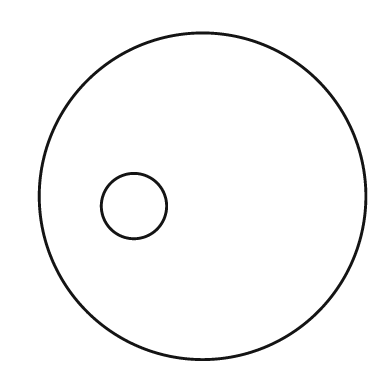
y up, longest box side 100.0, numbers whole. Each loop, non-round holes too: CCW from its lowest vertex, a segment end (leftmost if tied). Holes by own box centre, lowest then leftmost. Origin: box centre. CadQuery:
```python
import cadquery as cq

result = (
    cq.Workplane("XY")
    .moveTo(0.0, 0.0)
    .circle(50.0)
    .moveTo(-21.0, -3.0)
    .circle(10.0)
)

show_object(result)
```